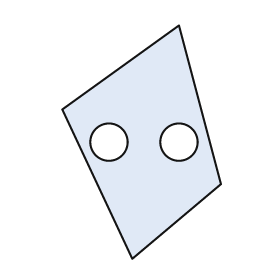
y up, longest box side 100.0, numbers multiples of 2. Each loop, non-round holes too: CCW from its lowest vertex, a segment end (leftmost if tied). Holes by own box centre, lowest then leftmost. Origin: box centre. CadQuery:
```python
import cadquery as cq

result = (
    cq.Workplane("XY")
    .moveTo(-4.0, -50.0)
    .lineTo(34.0, -18.0)
    .lineTo(16.0, 50.0)
    .lineTo(-34.0, 14.0)
    .close()
    .moveTo(-14.0, 0.0)
    .circle(8.0)
    .moveTo(16.0, 0.0)
    .circle(8.0)
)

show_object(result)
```